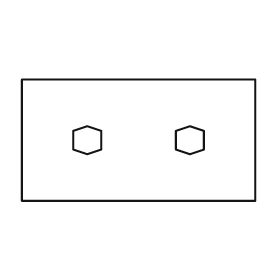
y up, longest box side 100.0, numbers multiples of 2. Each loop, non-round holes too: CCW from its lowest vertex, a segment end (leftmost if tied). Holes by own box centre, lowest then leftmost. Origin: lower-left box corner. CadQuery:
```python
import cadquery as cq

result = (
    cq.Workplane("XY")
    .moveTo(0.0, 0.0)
    .lineTo(100.0, 0.0)
    .lineTo(100.0, 52.0)
    .lineTo(0.0, 52.0)
    .close()
    .moveTo(28.0, 20.0)
    .lineTo(34.0, 22.0)
    .lineTo(34.0, 30.0)
    .lineTo(28.0, 32.0)
    .lineTo(22.0, 30.0)
    .lineTo(22.0, 22.0)
    .close()
    .moveTo(72.0, 20.0)
    .lineTo(78.0, 22.0)
    .lineTo(78.0, 30.0)
    .lineTo(72.0, 32.0)
    .lineTo(66.0, 30.0)
    .lineTo(66.0, 22.0)
    .close()
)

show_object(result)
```